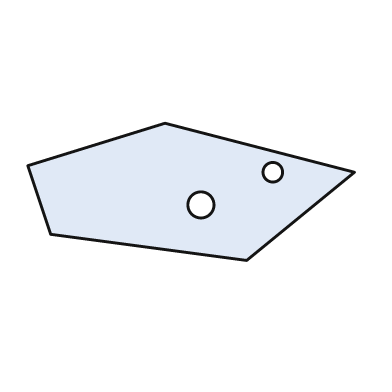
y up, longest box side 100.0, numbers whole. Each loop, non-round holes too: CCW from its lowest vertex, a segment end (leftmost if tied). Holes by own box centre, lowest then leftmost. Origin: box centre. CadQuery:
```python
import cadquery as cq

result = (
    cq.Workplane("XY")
    .moveTo(17.0, -21.0)
    .lineTo(50.0, 6.0)
    .lineTo(-8.0, 21.0)
    .lineTo(-50.0, 8.0)
    .lineTo(-43.0, -13.0)
    .close()
    .moveTo(3.0, -4.0)
    .circle(4.0)
    .moveTo(25.0, 6.0)
    .circle(3.0)
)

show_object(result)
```